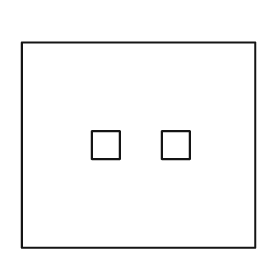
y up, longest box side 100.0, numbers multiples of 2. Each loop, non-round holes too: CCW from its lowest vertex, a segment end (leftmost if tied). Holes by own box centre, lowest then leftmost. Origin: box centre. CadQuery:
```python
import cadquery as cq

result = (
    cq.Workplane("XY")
    .moveTo(-50.0, -44.0)
    .lineTo(50.0, -44.0)
    .lineTo(50.0, 44.0)
    .lineTo(-50.0, 44.0)
    .close()
    .moveTo(-20.0, -6.0)
    .lineTo(-8.0, -6.0)
    .lineTo(-8.0, 6.0)
    .lineTo(-20.0, 6.0)
    .close()
    .moveTo(10.0, -6.0)
    .lineTo(22.0, -6.0)
    .lineTo(22.0, 6.0)
    .lineTo(10.0, 6.0)
    .close()
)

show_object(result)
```